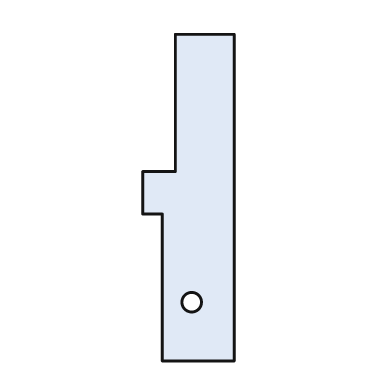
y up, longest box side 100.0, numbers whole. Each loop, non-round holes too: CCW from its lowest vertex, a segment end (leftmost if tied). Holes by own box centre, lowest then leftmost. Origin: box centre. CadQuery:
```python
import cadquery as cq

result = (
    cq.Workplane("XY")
    .moveTo(-8.0, -50.0)
    .lineTo(14.0, -50.0)
    .lineTo(14.0, 50.0)
    .lineTo(-4.0, 50.0)
    .lineTo(-4.0, 8.0)
    .lineTo(-14.0, 8.0)
    .lineTo(-14.0, -5.0)
    .lineTo(-8.0, -5.0)
    .close()
    .moveTo(1.0, -32.0)
    .circle(3.0)
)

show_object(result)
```